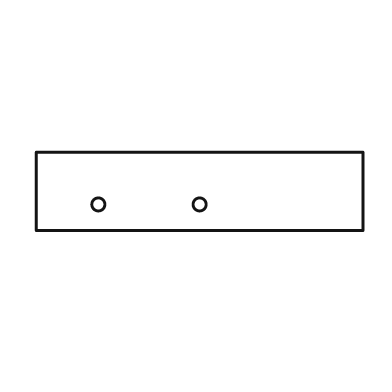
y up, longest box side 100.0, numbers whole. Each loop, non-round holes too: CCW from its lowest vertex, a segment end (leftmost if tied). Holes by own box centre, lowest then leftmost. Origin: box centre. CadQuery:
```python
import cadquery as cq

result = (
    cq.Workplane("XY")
    .moveTo(-50.0, -12.0)
    .lineTo(50.0, -12.0)
    .lineTo(50.0, 12.0)
    .lineTo(-50.0, 12.0)
    .close()
    .moveTo(-31.0, -4.0)
    .circle(2.0)
    .moveTo(0.0, -4.0)
    .circle(2.0)
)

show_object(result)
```